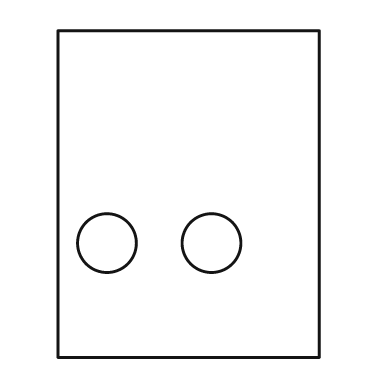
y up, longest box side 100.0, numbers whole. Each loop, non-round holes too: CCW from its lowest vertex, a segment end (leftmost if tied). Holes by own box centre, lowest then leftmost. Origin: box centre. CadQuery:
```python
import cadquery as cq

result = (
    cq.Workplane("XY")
    .moveTo(-40.0, -50.0)
    .lineTo(40.0, -50.0)
    .lineTo(40.0, 50.0)
    .lineTo(-40.0, 50.0)
    .close()
    .moveTo(-25.0, -15.0)
    .circle(9.0)
    .moveTo(7.0, -15.0)
    .circle(9.0)
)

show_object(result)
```